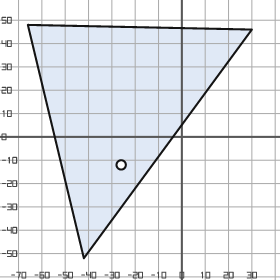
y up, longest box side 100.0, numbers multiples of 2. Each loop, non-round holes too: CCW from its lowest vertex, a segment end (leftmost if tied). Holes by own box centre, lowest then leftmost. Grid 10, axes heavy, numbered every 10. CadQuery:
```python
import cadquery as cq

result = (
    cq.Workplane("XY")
    .moveTo(-42.0, -52.0)
    .lineTo(30.0, 46.0)
    .lineTo(-66.0, 48.0)
    .close()
    .moveTo(-26.0, -12.0)
    .circle(2.0)
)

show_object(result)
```